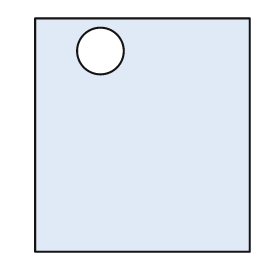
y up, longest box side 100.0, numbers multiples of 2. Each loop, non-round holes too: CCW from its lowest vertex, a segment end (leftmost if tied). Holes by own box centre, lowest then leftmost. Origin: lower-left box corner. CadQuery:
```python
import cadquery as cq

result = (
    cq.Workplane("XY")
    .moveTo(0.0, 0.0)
    .lineTo(92.0, 0.0)
    .lineTo(92.0, 100.0)
    .lineTo(0.0, 100.0)
    .close()
    .moveTo(28.0, 86.0)
    .circle(10.0)
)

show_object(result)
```